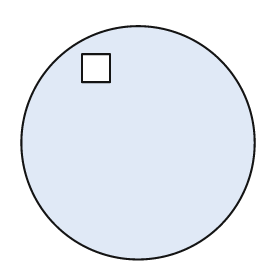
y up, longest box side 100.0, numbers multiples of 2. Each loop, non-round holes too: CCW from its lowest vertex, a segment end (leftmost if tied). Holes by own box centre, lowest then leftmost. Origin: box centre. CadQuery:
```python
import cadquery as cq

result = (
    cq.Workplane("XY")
    .moveTo(0.0, 0.0)
    .circle(50.0)
    .moveTo(-24.0, 26.0)
    .lineTo(-12.0, 26.0)
    .lineTo(-12.0, 38.0)
    .lineTo(-24.0, 38.0)
    .close()
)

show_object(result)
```